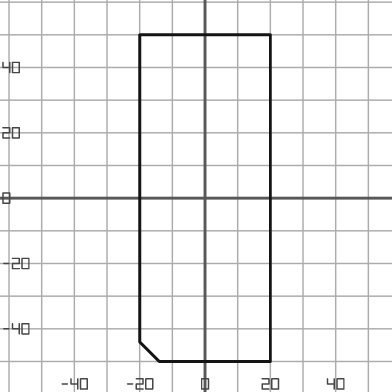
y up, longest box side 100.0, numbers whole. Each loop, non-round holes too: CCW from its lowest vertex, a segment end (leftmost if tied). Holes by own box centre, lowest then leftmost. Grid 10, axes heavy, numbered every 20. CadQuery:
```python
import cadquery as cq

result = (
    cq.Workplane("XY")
    .moveTo(-14.0, -50.0)
    .lineTo(20.0, -50.0)
    .lineTo(20.0, 50.0)
    .lineTo(-20.0, 50.0)
    .lineTo(-20.0, -44.0)
    .close()
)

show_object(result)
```